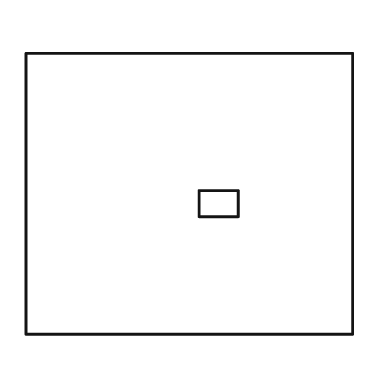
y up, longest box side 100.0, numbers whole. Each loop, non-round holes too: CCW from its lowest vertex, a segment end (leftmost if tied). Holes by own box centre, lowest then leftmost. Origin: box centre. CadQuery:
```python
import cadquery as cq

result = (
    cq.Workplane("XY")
    .moveTo(-50.0, -43.0)
    .lineTo(50.0, -43.0)
    .lineTo(50.0, 43.0)
    .lineTo(-50.0, 43.0)
    .close()
    .moveTo(3.0, -7.0)
    .lineTo(15.0, -7.0)
    .lineTo(15.0, 1.0)
    .lineTo(3.0, 1.0)
    .close()
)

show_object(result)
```